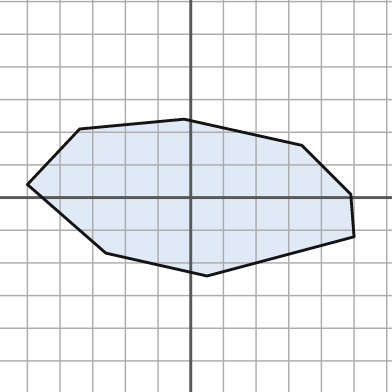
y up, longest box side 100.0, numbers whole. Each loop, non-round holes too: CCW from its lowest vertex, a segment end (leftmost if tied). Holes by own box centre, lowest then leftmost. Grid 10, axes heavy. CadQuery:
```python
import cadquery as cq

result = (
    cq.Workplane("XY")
    .moveTo(5.0, -24.0)
    .lineTo(50.0, -12.0)
    .lineTo(49.0, 1.0)
    .lineTo(34.0, 16.0)
    .lineTo(-2.0, 24.0)
    .lineTo(-34.0, 21.0)
    .lineTo(-50.0, 4.0)
    .lineTo(-26.0, -17.0)
    .close()
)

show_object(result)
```